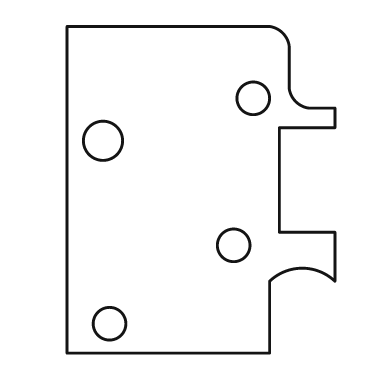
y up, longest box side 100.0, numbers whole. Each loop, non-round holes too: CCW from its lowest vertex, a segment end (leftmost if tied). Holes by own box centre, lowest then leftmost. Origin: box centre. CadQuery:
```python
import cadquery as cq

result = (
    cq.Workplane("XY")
    .moveTo(-41.0, -50.0)
    .lineTo(21.0, -50.0)
    .lineTo(21.0, -28.0)
    .threePointArc((31.0, -24.0), (41.0, -28.0))
    .lineTo(41.0, -13.0)
    .lineTo(24.0, -13.0)
    .lineTo(24.0, 19.0)
    .lineTo(41.0, 19.0)
    .lineTo(41.0, 25.0)
    .lineTo(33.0, 25.0)
    .threePointArc((29.0, 27.0), (27.0, 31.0))
    .lineTo(27.0, 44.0)
    .threePointArc((25.0, 48.0), (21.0, 50.0))
    .lineTo(-41.0, 50.0)
    .close()
    .moveTo(-28.0, -41.0)
    .circle(5.0)
    .moveTo(10.0, -17.0)
    .circle(5.0)
    .moveTo(-30.0, 15.0)
    .circle(6.0)
    .moveTo(16.0, 28.0)
    .circle(5.0)
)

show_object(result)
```